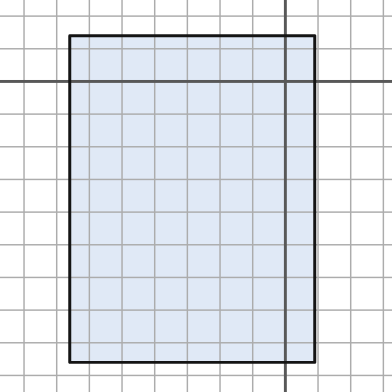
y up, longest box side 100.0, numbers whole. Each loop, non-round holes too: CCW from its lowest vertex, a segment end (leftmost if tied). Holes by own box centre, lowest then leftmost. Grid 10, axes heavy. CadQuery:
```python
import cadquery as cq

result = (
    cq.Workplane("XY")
    .moveTo(-66.0, -86.0)
    .lineTo(9.0, -86.0)
    .lineTo(9.0, 14.0)
    .lineTo(-66.0, 14.0)
    .close()
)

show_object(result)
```